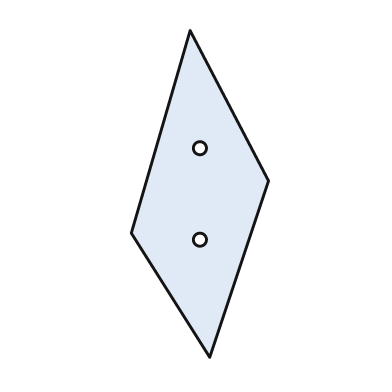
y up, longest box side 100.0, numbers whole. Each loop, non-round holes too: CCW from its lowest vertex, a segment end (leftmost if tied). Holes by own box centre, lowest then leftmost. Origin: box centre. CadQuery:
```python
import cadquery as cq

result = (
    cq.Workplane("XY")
    .moveTo(3.0, -50.0)
    .lineTo(21.0, 4.0)
    .lineTo(-3.0, 50.0)
    .lineTo(-21.0, -12.0)
    .close()
    .moveTo(0.0, -14.0)
    .circle(2.0)
    .moveTo(0.0, 14.0)
    .circle(2.0)
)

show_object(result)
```